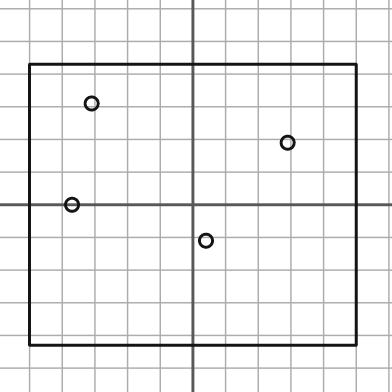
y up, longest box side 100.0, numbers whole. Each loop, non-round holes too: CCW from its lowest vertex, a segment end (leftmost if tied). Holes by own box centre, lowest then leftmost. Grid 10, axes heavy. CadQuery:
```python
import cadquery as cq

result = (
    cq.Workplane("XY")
    .moveTo(-50.0, -43.0)
    .lineTo(50.0, -43.0)
    .lineTo(50.0, 43.0)
    .lineTo(-50.0, 43.0)
    .close()
    .moveTo(4.0, -11.0)
    .circle(2.0)
    .moveTo(-37.0, 0.0)
    .circle(2.0)
    .moveTo(29.0, 19.0)
    .circle(2.0)
    .moveTo(-31.0, 31.0)
    .circle(2.0)
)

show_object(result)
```